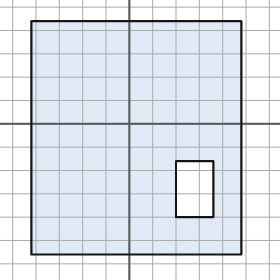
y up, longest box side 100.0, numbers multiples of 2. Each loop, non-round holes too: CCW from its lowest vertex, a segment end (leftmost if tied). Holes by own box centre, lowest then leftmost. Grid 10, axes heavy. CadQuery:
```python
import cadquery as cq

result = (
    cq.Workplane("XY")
    .moveTo(-42.0, -56.0)
    .lineTo(48.0, -56.0)
    .lineTo(48.0, 44.0)
    .lineTo(-42.0, 44.0)
    .close()
    .moveTo(20.0, -40.0)
    .lineTo(36.0, -40.0)
    .lineTo(36.0, -16.0)
    .lineTo(20.0, -16.0)
    .close()
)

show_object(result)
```